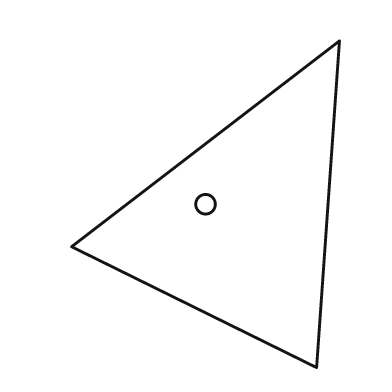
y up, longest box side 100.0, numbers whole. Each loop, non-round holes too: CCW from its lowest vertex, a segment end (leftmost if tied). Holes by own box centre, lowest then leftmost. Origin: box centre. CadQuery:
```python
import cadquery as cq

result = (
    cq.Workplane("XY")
    .moveTo(34.0, -50.0)
    .lineTo(41.0, 50.0)
    .lineTo(-41.0, -13.0)
    .close()
    .moveTo(0.0, 0.0)
    .circle(3.0)
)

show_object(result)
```